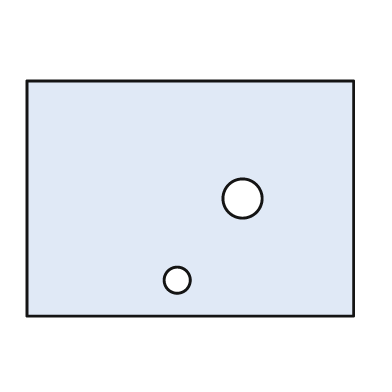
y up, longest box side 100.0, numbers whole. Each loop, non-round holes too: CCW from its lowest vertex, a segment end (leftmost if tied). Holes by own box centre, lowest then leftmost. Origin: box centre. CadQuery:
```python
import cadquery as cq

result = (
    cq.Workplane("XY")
    .moveTo(-50.0, -36.0)
    .lineTo(50.0, -36.0)
    .lineTo(50.0, 36.0)
    .lineTo(-50.0, 36.0)
    .close()
    .moveTo(-4.0, -25.0)
    .circle(4.0)
    .moveTo(16.0, 0.0)
    .circle(6.0)
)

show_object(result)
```